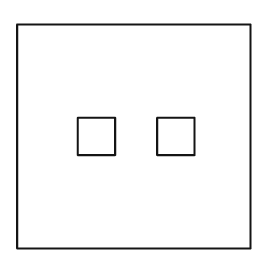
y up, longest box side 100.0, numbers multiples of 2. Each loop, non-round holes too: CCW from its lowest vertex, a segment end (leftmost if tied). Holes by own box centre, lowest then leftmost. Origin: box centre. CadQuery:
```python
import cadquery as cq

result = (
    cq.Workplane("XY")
    .moveTo(-50.0, -48.0)
    .lineTo(50.0, -48.0)
    .lineTo(50.0, 48.0)
    .lineTo(-50.0, 48.0)
    .close()
    .moveTo(-24.0, -8.0)
    .lineTo(-8.0, -8.0)
    .lineTo(-8.0, 8.0)
    .lineTo(-24.0, 8.0)
    .close()
    .moveTo(10.0, -8.0)
    .lineTo(26.0, -8.0)
    .lineTo(26.0, 8.0)
    .lineTo(10.0, 8.0)
    .close()
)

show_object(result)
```